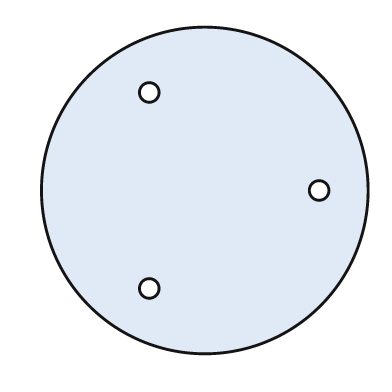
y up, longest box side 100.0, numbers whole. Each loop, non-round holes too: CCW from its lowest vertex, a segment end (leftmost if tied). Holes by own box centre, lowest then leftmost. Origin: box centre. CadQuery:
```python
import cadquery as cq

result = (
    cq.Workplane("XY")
    .moveTo(0.0, 0.0)
    .circle(50.0)
    .moveTo(-17.0, -30.0)
    .circle(3.0)
    .moveTo(35.0, 0.0)
    .circle(3.0)
    .moveTo(-17.0, 30.0)
    .circle(3.0)
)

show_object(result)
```